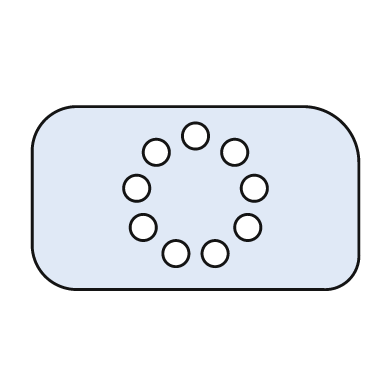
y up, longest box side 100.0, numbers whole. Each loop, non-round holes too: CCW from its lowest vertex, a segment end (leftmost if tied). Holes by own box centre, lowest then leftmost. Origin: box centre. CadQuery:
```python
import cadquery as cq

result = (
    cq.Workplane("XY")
    .moveTo(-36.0, -28.0)
    .lineTo(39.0, -28.0)
    .threePointArc((47.0, -25.0), (50.0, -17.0))
    .lineTo(50.0, 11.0)
    .threePointArc((45.0, 23.0), (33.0, 28.0))
    .lineTo(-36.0, 28.0)
    .threePointArc((-46.0, 24.0), (-50.0, 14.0))
    .lineTo(-50.0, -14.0)
    .threePointArc((-46.0, -24.0), (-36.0, -28.0))
    .close()
    .moveTo(-6.0, -17.0)
    .circle(4.0)
    .moveTo(6.0, -17.0)
    .circle(4.0)
    .moveTo(-16.0, -9.0)
    .circle(4.0)
    .moveTo(16.0, -9.0)
    .circle(4.0)
    .moveTo(-18.0, 3.0)
    .circle(4.0)
    .moveTo(18.0, 3.0)
    .circle(4.0)
    .moveTo(-12.0, 14.0)
    .circle(4.0)
    .moveTo(12.0, 14.0)
    .circle(4.0)
    .moveTo(0.0, 19.0)
    .circle(4.0)
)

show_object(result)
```